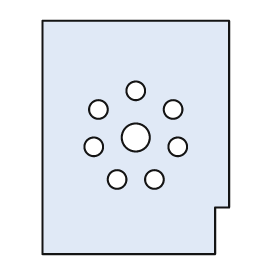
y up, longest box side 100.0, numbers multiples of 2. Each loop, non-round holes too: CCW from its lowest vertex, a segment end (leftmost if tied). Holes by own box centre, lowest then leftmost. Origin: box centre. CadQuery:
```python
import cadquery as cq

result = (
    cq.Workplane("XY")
    .moveTo(-40.0, -50.0)
    .lineTo(34.0, -50.0)
    .lineTo(34.0, -30.0)
    .lineTo(40.0, -30.0)
    .lineTo(40.0, 50.0)
    .lineTo(-40.0, 50.0)
    .close()
    .moveTo(-8.0, -18.0)
    .circle(4.0)
    .moveTo(8.0, -18.0)
    .circle(4.0)
    .moveTo(-18.0, -4.0)
    .circle(4.0)
    .moveTo(18.0, -4.0)
    .circle(4.0)
    .moveTo(0.0, 0.0)
    .circle(6.0)
    .moveTo(-16.0, 12.0)
    .circle(4.0)
    .moveTo(16.0, 12.0)
    .circle(4.0)
    .moveTo(0.0, 20.0)
    .circle(4.0)
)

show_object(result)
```